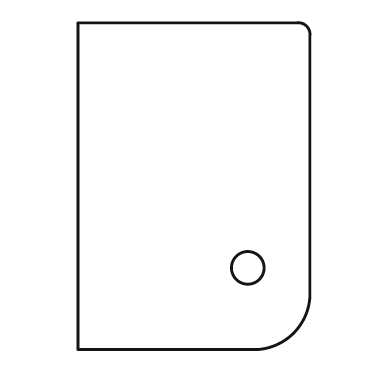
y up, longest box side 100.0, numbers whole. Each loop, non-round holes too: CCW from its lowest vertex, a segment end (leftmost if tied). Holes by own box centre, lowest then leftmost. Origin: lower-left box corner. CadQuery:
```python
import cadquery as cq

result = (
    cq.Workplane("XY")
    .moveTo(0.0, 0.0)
    .lineTo(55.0, 0.0)
    .threePointArc((66.0, 5.0), (71.0, 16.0))
    .lineTo(71.0, 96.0)
    .threePointArc((70.0, 99.0), (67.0, 100.0))
    .lineTo(0.0, 100.0)
    .close()
    .moveTo(52.0, 25.0)
    .circle(5.0)
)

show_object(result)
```